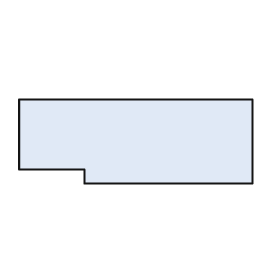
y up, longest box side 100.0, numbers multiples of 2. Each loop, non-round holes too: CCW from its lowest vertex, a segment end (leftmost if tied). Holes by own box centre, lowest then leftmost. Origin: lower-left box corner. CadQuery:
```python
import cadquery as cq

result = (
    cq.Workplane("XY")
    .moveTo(28.0, 0.0)
    .lineTo(100.0, 0.0)
    .lineTo(100.0, 36.0)
    .lineTo(0.0, 36.0)
    .lineTo(0.0, 6.0)
    .lineTo(28.0, 6.0)
    .close()
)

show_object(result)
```